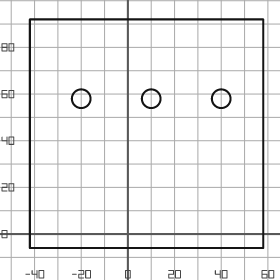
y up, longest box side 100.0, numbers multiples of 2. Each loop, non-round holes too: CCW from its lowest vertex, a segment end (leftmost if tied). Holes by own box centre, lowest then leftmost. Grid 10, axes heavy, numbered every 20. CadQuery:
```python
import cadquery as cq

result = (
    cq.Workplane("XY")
    .moveTo(-42.0, -6.0)
    .lineTo(58.0, -6.0)
    .lineTo(58.0, 92.0)
    .lineTo(-42.0, 92.0)
    .close()
    .moveTo(-20.0, 58.0)
    .circle(4.0)
    .moveTo(10.0, 58.0)
    .circle(4.0)
    .moveTo(40.0, 58.0)
    .circle(4.0)
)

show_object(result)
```